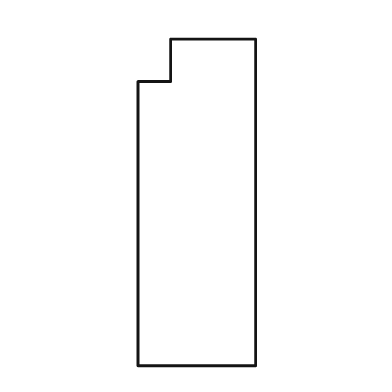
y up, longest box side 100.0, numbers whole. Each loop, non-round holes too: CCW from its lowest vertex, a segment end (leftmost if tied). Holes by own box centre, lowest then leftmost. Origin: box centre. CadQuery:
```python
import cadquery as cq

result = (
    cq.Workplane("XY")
    .moveTo(-18.0, -50.0)
    .lineTo(18.0, -50.0)
    .lineTo(18.0, 50.0)
    .lineTo(-8.0, 50.0)
    .lineTo(-8.0, 37.0)
    .lineTo(-18.0, 37.0)
    .close()
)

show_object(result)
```